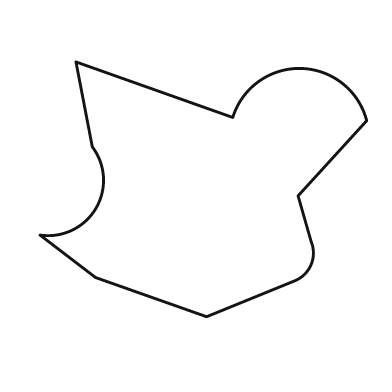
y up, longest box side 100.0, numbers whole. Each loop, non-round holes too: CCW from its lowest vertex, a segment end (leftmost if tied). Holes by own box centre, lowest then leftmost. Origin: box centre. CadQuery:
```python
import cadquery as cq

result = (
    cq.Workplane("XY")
    .moveTo(1.0, -39.0)
    .lineTo(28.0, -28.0)
    .threePointArc((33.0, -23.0), (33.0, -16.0))
    .lineTo(29.0, -2.0)
    .lineTo(50.0, 21.0)
    .threePointArc((30.0, 37.0), (9.0, 22.0))
    .lineTo(-39.0, 39.0)
    .lineTo(-34.0, 13.0)
    .threePointArc((-33.0, -6.0), (-50.0, -14.0))
    .lineTo(-33.0, -27.0)
    .close()
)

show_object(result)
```